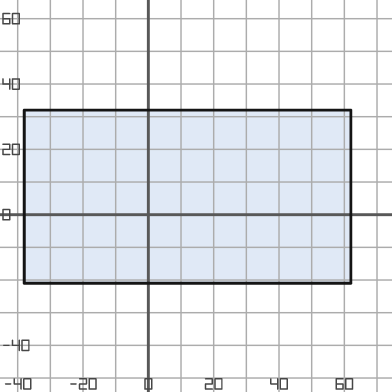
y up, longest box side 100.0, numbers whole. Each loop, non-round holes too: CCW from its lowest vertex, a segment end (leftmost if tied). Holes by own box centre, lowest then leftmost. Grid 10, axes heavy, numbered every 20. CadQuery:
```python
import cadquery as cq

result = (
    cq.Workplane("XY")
    .moveTo(-38.0, -21.0)
    .lineTo(62.0, -21.0)
    .lineTo(62.0, 32.0)
    .lineTo(-38.0, 32.0)
    .close()
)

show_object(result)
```